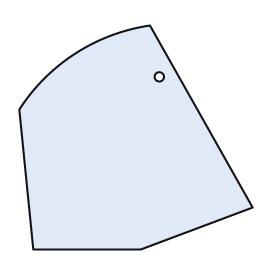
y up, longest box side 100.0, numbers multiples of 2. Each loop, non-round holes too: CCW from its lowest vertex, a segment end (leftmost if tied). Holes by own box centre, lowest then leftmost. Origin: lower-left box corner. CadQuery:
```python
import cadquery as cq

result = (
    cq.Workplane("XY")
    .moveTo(6.0, 0.0)
    .lineTo(52.0, 0.0)
    .lineTo(100.0, 18.0)
    .lineTo(56.0, 96.0)
    .threePointArc((24.0, 84.0), (0.0, 60.0))
    .close()
    .moveTo(60.0, 74.0)
    .circle(2.0)
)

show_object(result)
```